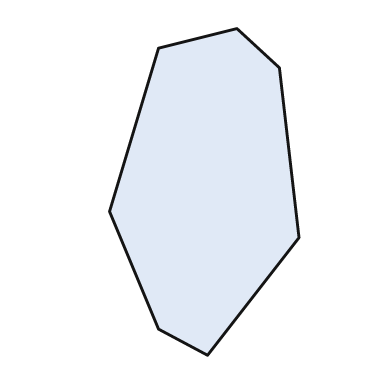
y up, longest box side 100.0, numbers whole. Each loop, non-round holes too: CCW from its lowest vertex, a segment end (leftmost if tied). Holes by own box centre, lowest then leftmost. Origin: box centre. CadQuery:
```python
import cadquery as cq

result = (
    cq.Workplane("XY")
    .moveTo(1.0, -50.0)
    .lineTo(29.0, -14.0)
    .lineTo(23.0, 38.0)
    .lineTo(10.0, 50.0)
    .lineTo(-14.0, 44.0)
    .lineTo(-29.0, -6.0)
    .lineTo(-14.0, -42.0)
    .close()
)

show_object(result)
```